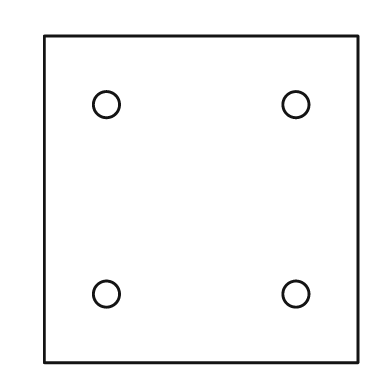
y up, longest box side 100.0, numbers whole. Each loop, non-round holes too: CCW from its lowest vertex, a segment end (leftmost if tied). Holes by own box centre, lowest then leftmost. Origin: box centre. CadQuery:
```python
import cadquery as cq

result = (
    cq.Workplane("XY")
    .moveTo(-48.0, -50.0)
    .lineTo(48.0, -50.0)
    .lineTo(48.0, 50.0)
    .lineTo(-48.0, 50.0)
    .close()
    .moveTo(-29.0, -29.0)
    .circle(4.0)
    .moveTo(29.0, -29.0)
    .circle(4.0)
    .moveTo(-29.0, 29.0)
    .circle(4.0)
    .moveTo(29.0, 29.0)
    .circle(4.0)
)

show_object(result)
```